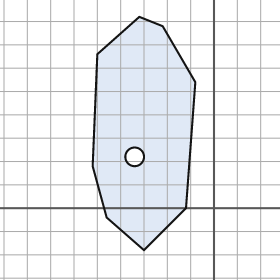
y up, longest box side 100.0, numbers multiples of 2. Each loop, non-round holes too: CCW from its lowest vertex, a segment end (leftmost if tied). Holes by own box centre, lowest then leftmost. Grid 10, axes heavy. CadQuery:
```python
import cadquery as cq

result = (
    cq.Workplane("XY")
    .moveTo(-30.0, -18.0)
    .lineTo(-12.0, 0.0)
    .lineTo(-8.0, 54.0)
    .lineTo(-22.0, 78.0)
    .lineTo(-32.0, 82.0)
    .lineTo(-50.0, 66.0)
    .lineTo(-52.0, 18.0)
    .lineTo(-46.0, -4.0)
    .close()
    .moveTo(-34.0, 22.0)
    .circle(4.0)
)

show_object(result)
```